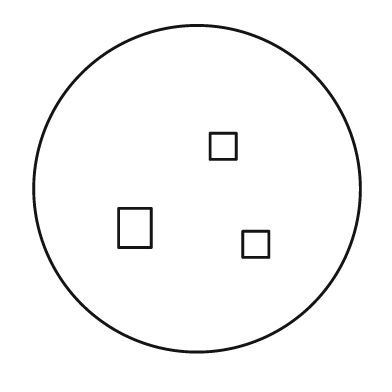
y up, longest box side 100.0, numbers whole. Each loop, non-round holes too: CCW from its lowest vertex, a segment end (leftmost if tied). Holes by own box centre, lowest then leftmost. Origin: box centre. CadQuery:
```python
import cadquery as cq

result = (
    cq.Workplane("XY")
    .moveTo(0.0, 0.0)
    .circle(50.0)
    .moveTo(14.0, -21.0)
    .lineTo(22.0, -21.0)
    .lineTo(22.0, -13.0)
    .lineTo(14.0, -13.0)
    .close()
    .moveTo(-24.0, -18.0)
    .lineTo(-14.0, -18.0)
    .lineTo(-14.0, -6.0)
    .lineTo(-24.0, -6.0)
    .close()
    .moveTo(4.0, 9.0)
    .lineTo(12.0, 9.0)
    .lineTo(12.0, 17.0)
    .lineTo(4.0, 17.0)
    .close()
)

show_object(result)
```